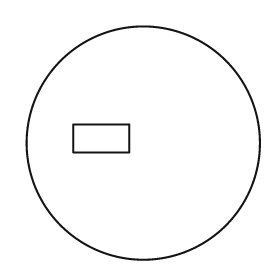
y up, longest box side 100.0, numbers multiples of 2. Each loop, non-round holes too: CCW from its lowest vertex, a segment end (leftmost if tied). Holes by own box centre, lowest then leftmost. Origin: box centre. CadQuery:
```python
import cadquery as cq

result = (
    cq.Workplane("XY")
    .moveTo(0.0, 0.0)
    .circle(50.0)
    .moveTo(-30.0, -4.0)
    .lineTo(-6.0, -4.0)
    .lineTo(-6.0, 8.0)
    .lineTo(-30.0, 8.0)
    .close()
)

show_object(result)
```